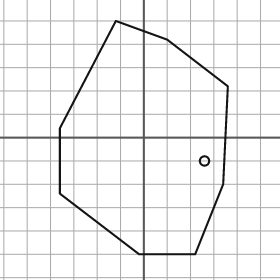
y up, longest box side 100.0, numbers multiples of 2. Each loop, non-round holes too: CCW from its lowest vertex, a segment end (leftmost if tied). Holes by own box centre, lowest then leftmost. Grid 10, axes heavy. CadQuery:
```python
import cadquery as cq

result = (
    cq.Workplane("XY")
    .moveTo(-2.0, -50.0)
    .lineTo(22.0, -50.0)
    .lineTo(34.0, -20.0)
    .lineTo(36.0, 22.0)
    .lineTo(10.0, 42.0)
    .lineTo(-12.0, 50.0)
    .lineTo(-36.0, 4.0)
    .lineTo(-36.0, -24.0)
    .close()
    .moveTo(26.0, -10.0)
    .circle(2.0)
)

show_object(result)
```